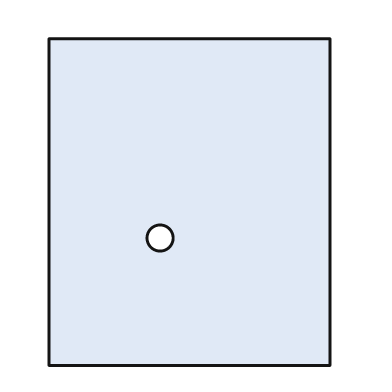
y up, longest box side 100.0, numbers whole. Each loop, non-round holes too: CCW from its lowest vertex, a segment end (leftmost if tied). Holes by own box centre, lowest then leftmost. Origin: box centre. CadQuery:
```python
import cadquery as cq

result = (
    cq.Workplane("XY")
    .moveTo(-43.0, -50.0)
    .lineTo(43.0, -50.0)
    .lineTo(43.0, 50.0)
    .lineTo(-43.0, 50.0)
    .close()
    .moveTo(-9.0, -11.0)
    .circle(4.0)
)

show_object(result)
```